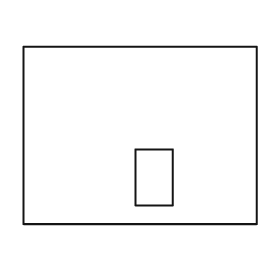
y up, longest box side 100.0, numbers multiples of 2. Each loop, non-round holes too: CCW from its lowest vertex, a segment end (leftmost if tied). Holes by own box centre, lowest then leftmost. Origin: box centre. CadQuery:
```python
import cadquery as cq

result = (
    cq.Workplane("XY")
    .moveTo(-50.0, -38.0)
    .lineTo(50.0, -38.0)
    .lineTo(50.0, 38.0)
    .lineTo(-50.0, 38.0)
    .close()
    .moveTo(-2.0, -30.0)
    .lineTo(14.0, -30.0)
    .lineTo(14.0, -6.0)
    .lineTo(-2.0, -6.0)
    .close()
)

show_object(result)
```